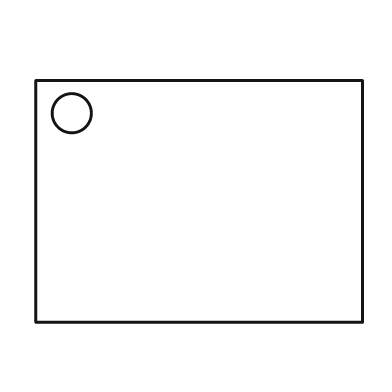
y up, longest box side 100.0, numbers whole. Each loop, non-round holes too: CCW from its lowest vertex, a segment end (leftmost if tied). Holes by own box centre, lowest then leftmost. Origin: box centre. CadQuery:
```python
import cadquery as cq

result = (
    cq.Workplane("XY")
    .moveTo(-50.0, -37.0)
    .lineTo(50.0, -37.0)
    .lineTo(50.0, 37.0)
    .lineTo(-50.0, 37.0)
    .close()
    .moveTo(-39.0, 27.0)
    .circle(6.0)
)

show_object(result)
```